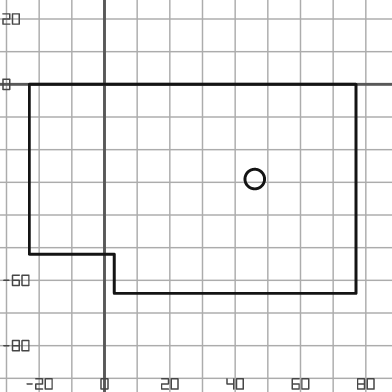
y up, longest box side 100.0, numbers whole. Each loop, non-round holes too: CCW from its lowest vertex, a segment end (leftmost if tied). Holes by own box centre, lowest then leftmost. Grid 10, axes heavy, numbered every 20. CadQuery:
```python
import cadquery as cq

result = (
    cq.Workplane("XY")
    .moveTo(3.0, -64.0)
    .lineTo(77.0, -64.0)
    .lineTo(77.0, 0.0)
    .lineTo(-23.0, 0.0)
    .lineTo(-23.0, -52.0)
    .lineTo(3.0, -52.0)
    .close()
    .moveTo(46.0, -29.0)
    .circle(3.0)
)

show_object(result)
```